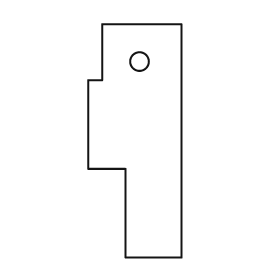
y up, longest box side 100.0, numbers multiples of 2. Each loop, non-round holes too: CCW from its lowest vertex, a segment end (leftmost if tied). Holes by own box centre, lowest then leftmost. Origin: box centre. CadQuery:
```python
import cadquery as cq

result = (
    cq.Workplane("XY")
    .moveTo(-4.0, -50.0)
    .lineTo(20.0, -50.0)
    .lineTo(20.0, 50.0)
    .lineTo(-14.0, 50.0)
    .lineTo(-14.0, 26.0)
    .lineTo(-20.0, 26.0)
    .lineTo(-20.0, -12.0)
    .lineTo(-4.0, -12.0)
    .close()
    .moveTo(2.0, 34.0)
    .circle(4.0)
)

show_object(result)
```